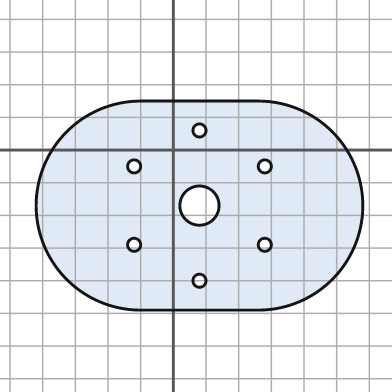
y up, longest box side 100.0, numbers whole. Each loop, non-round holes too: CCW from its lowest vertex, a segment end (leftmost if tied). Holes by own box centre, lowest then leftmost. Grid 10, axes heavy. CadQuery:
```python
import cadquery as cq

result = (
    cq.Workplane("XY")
    .moveTo(-10.0, -49.0)
    .lineTo(26.0, -49.0)
    .threePointArc((58.0, -17.0), (26.0, 15.0))
    .lineTo(-10.0, 15.0)
    .threePointArc((-42.0, -17.0), (-10.0, -49.0))
    .close()
    .moveTo(8.0, -40.0)
    .circle(2.0)
    .moveTo(-12.0, -29.0)
    .circle(2.0)
    .moveTo(28.0, -29.0)
    .circle(2.0)
    .moveTo(8.0, -17.0)
    .circle(6.0)
    .moveTo(-12.0, -5.0)
    .circle(2.0)
    .moveTo(28.0, -5.0)
    .circle(2.0)
    .moveTo(8.0, 6.0)
    .circle(2.0)
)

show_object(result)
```